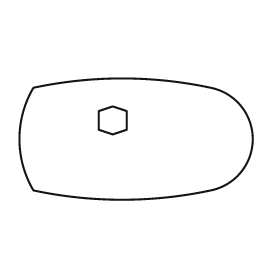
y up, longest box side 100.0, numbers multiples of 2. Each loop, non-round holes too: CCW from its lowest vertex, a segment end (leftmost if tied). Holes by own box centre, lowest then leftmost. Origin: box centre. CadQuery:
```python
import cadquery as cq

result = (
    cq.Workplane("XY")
    .moveTo(-44.0, -22.0)
    .threePointArc((-6.0, -26.0), (32.0, -22.0))
    .threePointArc((50.0, 0.0), (32.0, 22.0))
    .threePointArc((-6.0, 26.0), (-44.0, 22.0))
    .threePointArc((-50.0, 0.0), (-44.0, -22.0))
    .close()
    .moveTo(-10.0, 2.0)
    .lineTo(-4.0, 4.0)
    .lineTo(-4.0, 12.0)
    .lineTo(-10.0, 14.0)
    .lineTo(-16.0, 12.0)
    .lineTo(-16.0, 4.0)
    .close()
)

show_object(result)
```